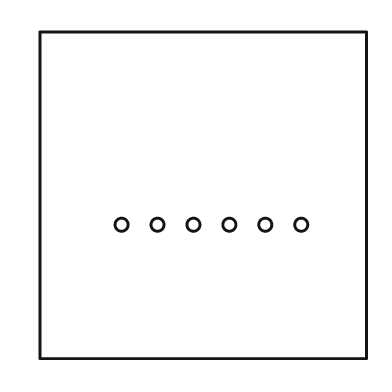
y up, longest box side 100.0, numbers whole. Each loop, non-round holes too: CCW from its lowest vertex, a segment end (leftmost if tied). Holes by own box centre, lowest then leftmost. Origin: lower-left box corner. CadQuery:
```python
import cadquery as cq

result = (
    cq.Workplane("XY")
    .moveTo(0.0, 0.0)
    .lineTo(100.0, 0.0)
    .lineTo(100.0, 100.0)
    .lineTo(0.0, 100.0)
    .close()
    .moveTo(25.0, 41.0)
    .circle(2.0)
    .moveTo(36.0, 41.0)
    .circle(2.0)
    .moveTo(47.0, 41.0)
    .circle(2.0)
    .moveTo(58.0, 41.0)
    .circle(2.0)
    .moveTo(69.0, 41.0)
    .circle(2.0)
    .moveTo(80.0, 41.0)
    .circle(2.0)
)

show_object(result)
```